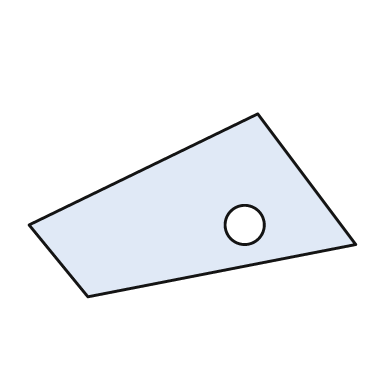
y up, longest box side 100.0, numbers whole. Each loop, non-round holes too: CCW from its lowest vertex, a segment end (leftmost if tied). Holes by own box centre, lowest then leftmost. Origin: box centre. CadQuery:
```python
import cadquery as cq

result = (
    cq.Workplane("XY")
    .moveTo(-32.0, -28.0)
    .lineTo(50.0, -12.0)
    .lineTo(20.0, 28.0)
    .lineTo(-50.0, -6.0)
    .close()
    .moveTo(16.0, -6.0)
    .circle(6.0)
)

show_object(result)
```